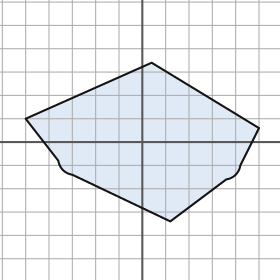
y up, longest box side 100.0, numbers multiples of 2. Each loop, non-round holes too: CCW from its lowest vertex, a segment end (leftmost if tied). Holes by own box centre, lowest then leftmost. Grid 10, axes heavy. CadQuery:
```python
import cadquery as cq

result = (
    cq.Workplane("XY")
    .moveTo(12.0, -34.0)
    .lineTo(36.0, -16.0)
    .threePointArc((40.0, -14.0), (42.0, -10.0))
    .lineTo(50.0, 6.0)
    .lineTo(4.0, 34.0)
    .lineTo(-50.0, 10.0)
    .lineTo(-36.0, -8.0)
    .threePointArc((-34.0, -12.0), (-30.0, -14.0))
    .close()
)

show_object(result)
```